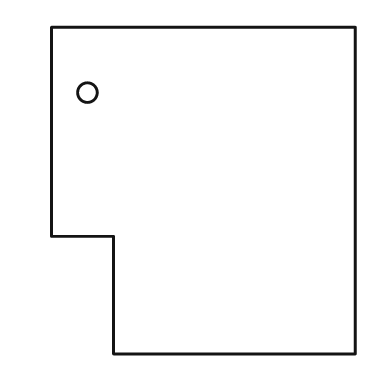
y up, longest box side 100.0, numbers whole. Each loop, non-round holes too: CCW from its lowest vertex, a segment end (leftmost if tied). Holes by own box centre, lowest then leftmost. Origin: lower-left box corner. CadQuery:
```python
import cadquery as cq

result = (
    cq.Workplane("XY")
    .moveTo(19.0, 0.0)
    .lineTo(93.0, 0.0)
    .lineTo(93.0, 100.0)
    .lineTo(0.0, 100.0)
    .lineTo(0.0, 36.0)
    .lineTo(19.0, 36.0)
    .close()
    .moveTo(11.0, 80.0)
    .circle(3.0)
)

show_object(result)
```